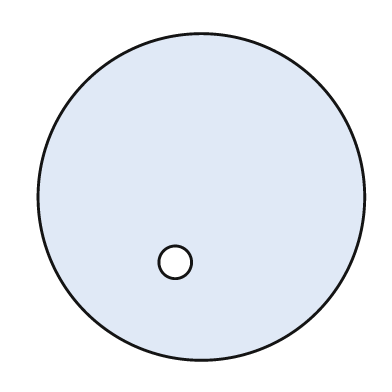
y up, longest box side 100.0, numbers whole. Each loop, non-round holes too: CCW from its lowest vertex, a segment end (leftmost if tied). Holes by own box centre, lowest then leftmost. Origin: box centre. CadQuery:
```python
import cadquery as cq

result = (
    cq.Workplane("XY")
    .moveTo(0.0, 0.0)
    .circle(50.0)
    .moveTo(-8.0, -20.0)
    .circle(5.0)
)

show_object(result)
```